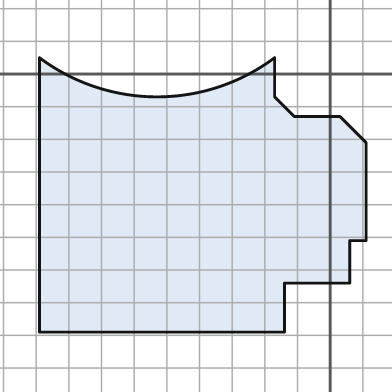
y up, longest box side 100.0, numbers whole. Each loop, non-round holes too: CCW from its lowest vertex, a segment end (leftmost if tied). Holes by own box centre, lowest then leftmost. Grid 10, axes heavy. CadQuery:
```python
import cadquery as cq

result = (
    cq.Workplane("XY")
    .moveTo(-89.0, -79.0)
    .lineTo(-14.0, -79.0)
    .lineTo(-14.0, -64.0)
    .lineTo(6.0, -64.0)
    .lineTo(6.0, -51.0)
    .lineTo(11.0, -51.0)
    .lineTo(11.0, -21.0)
    .lineTo(3.0, -13.0)
    .lineTo(-11.0, -13.0)
    .lineTo(-17.0, -7.0)
    .lineTo(-17.0, 5.0)
    .threePointArc((-53.0, -7.0), (-89.0, 5.0))
    .close()
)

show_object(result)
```